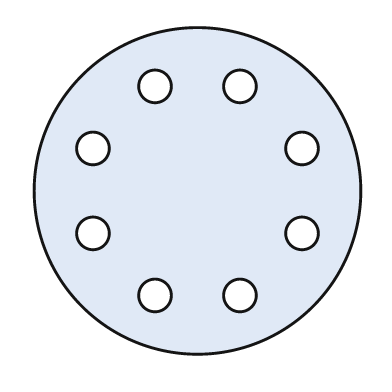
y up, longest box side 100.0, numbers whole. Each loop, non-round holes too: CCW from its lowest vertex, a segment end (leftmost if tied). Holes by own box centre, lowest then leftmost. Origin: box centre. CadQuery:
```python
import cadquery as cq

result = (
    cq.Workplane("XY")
    .moveTo(0.0, 0.0)
    .circle(50.0)
    .moveTo(-13.0, -32.0)
    .circle(5.0)
    .moveTo(13.0, -32.0)
    .circle(5.0)
    .moveTo(-32.0, -13.0)
    .circle(5.0)
    .moveTo(32.0, -13.0)
    .circle(5.0)
    .moveTo(-32.0, 13.0)
    .circle(5.0)
    .moveTo(32.0, 13.0)
    .circle(5.0)
    .moveTo(-13.0, 32.0)
    .circle(5.0)
    .moveTo(13.0, 32.0)
    .circle(5.0)
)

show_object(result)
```